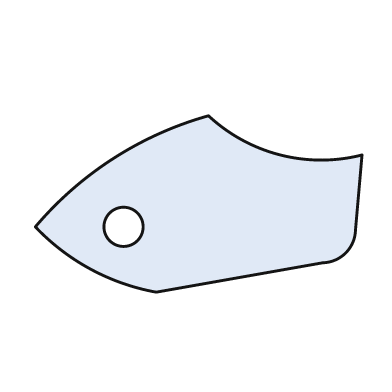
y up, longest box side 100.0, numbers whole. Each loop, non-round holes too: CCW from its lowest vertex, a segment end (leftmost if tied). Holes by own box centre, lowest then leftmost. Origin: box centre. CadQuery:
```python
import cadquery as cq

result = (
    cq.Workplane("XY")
    .moveTo(-13.0, -27.0)
    .lineTo(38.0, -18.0)
    .threePointArc((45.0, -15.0), (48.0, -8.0))
    .lineTo(50.0, 15.0)
    .threePointArc((25.0, 15.0), (3.0, 27.0))
    .threePointArc((-26.0, 14.0), (-50.0, -7.0))
    .threePointArc((-33.0, -20.0), (-13.0, -27.0))
    .close()
    .moveTo(-23.0, -7.0)
    .circle(6.0)
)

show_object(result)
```